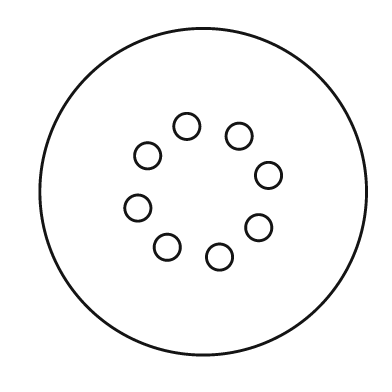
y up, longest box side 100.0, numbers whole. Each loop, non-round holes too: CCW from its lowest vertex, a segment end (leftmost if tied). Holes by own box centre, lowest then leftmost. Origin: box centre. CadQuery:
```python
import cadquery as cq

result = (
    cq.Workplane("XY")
    .moveTo(0.0, 0.0)
    .circle(50.0)
    .moveTo(5.0, -20.0)
    .circle(4.0)
    .moveTo(-11.0, -17.0)
    .circle(4.0)
    .moveTo(17.0, -11.0)
    .circle(4.0)
    .moveTo(-20.0, -5.0)
    .circle(4.0)
    .moveTo(20.0, 5.0)
    .circle(4.0)
    .moveTo(-17.0, 11.0)
    .circle(4.0)
    .moveTo(11.0, 17.0)
    .circle(4.0)
    .moveTo(-5.0, 20.0)
    .circle(4.0)
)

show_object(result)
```